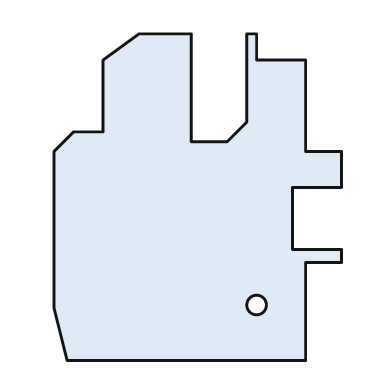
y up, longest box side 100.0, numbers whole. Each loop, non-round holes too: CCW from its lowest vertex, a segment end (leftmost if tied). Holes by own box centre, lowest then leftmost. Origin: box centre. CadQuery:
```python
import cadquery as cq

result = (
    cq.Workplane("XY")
    .moveTo(-40.0, -50.0)
    .lineTo(33.0, -50.0)
    .lineTo(33.0, -20.0)
    .lineTo(44.0, -20.0)
    .lineTo(44.0, -16.0)
    .lineTo(29.0, -16.0)
    .lineTo(29.0, 3.0)
    .lineTo(44.0, 3.0)
    .lineTo(44.0, 14.0)
    .lineTo(33.0, 14.0)
    .lineTo(33.0, 42.0)
    .lineTo(18.0, 42.0)
    .lineTo(18.0, 50.0)
    .lineTo(15.0, 50.0)
    .lineTo(15.0, 23.0)
    .lineTo(9.0, 17.0)
    .lineTo(-2.0, 17.0)
    .lineTo(-2.0, 50.0)
    .lineTo(-18.0, 50.0)
    .lineTo(-29.0, 42.0)
    .lineTo(-29.0, 20.0)
    .lineTo(-38.0, 20.0)
    .lineTo(-44.0, 14.0)
    .lineTo(-44.0, -34.0)
    .close()
    .moveTo(18.0, -33.0)
    .circle(3.0)
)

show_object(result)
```